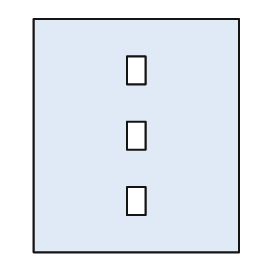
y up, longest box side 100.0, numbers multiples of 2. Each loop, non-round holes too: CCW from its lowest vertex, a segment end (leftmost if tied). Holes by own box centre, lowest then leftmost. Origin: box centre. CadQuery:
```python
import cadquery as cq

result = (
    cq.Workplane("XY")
    .moveTo(-44.0, -50.0)
    .lineTo(44.0, -50.0)
    .lineTo(44.0, 50.0)
    .lineTo(-44.0, 50.0)
    .close()
    .moveTo(-4.0, -34.0)
    .lineTo(4.0, -34.0)
    .lineTo(4.0, -22.0)
    .lineTo(-4.0, -22.0)
    .close()
    .moveTo(-4.0, -6.0)
    .lineTo(4.0, -6.0)
    .lineTo(4.0, 6.0)
    .lineTo(-4.0, 6.0)
    .close()
    .moveTo(-4.0, 22.0)
    .lineTo(4.0, 22.0)
    .lineTo(4.0, 34.0)
    .lineTo(-4.0, 34.0)
    .close()
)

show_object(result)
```